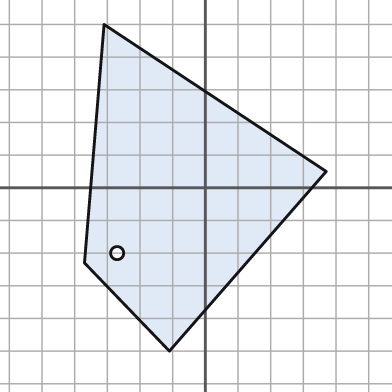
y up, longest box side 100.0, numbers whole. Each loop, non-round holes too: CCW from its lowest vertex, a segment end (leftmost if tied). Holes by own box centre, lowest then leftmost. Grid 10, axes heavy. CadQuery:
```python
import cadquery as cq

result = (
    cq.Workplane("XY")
    .moveTo(-11.0, -50.0)
    .lineTo(37.0, 5.0)
    .lineTo(-31.0, 50.0)
    .lineTo(-37.0, -23.0)
    .close()
    .moveTo(-27.0, -20.0)
    .circle(2.0)
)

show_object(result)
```